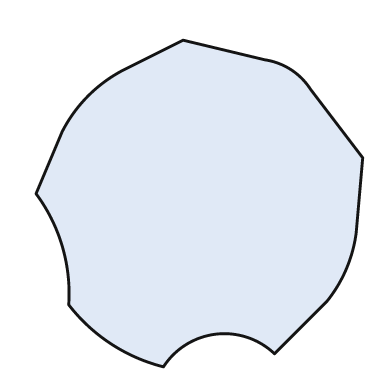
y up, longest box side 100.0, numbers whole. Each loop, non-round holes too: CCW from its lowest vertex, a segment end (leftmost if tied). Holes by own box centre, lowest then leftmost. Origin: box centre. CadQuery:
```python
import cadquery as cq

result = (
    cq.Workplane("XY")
    .moveTo(-11.0, -50.0)
    .threePointArc((5.0, -40.0), (23.0, -46.0))
    .lineTo(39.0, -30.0)
    .threePointArc((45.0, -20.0), (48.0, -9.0))
    .lineTo(50.0, 14.0)
    .lineTo(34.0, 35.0)
    .threePointArc((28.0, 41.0), (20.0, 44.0))
    .lineTo(-5.0, 50.0)
    .lineTo(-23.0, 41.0)
    .threePointArc((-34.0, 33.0), (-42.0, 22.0))
    .lineTo(-50.0, 3.0)
    .threePointArc((-42.0, -13.0), (-40.0, -31.0))
    .threePointArc((-27.0, -43.0), (-11.0, -50.0))
    .close()
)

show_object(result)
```